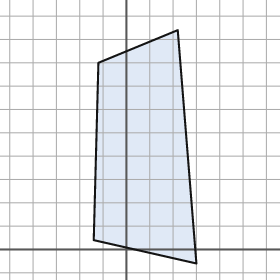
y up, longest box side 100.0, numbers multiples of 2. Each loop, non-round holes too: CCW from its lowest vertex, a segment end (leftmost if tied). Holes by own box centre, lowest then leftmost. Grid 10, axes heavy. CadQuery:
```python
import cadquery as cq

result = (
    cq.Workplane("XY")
    .moveTo(30.0, -6.0)
    .lineTo(22.0, 94.0)
    .lineTo(-12.0, 80.0)
    .lineTo(-14.0, 4.0)
    .close()
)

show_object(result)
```